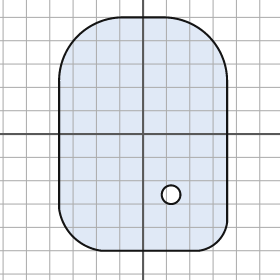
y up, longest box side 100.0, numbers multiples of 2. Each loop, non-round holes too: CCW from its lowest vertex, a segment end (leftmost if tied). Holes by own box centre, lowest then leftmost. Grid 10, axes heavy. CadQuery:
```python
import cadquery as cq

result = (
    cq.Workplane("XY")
    .moveTo(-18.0, -50.0)
    .lineTo(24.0, -50.0)
    .threePointArc((32.0, -46.0), (36.0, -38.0))
    .lineTo(36.0, 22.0)
    .threePointArc((28.0, 42.0), (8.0, 50.0))
    .lineTo(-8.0, 50.0)
    .threePointArc((-28.0, 42.0), (-36.0, 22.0))
    .lineTo(-36.0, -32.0)
    .threePointArc((-30.0, -44.0), (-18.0, -50.0))
    .close()
    .moveTo(12.0, -26.0)
    .circle(4.0)
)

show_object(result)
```